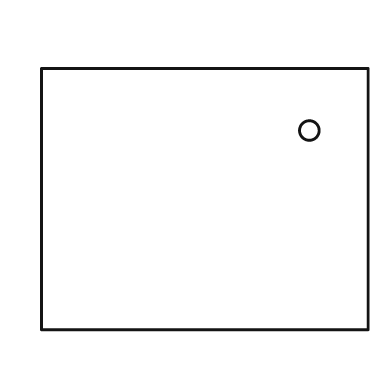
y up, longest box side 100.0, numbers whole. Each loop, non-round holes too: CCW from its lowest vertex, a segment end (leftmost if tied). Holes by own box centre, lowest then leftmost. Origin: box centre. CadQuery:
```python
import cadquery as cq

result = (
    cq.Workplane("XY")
    .moveTo(-50.0, -40.0)
    .lineTo(50.0, -40.0)
    .lineTo(50.0, 40.0)
    .lineTo(-50.0, 40.0)
    .close()
    .moveTo(32.0, 21.0)
    .circle(3.0)
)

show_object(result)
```